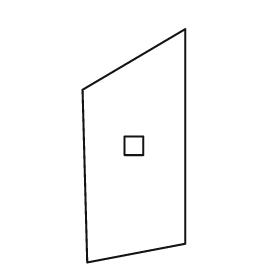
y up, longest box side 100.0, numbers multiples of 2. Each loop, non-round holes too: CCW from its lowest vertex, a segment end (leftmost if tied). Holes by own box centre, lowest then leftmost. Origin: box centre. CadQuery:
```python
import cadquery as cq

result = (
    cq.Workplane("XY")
    .moveTo(-20.0, -50.0)
    .lineTo(22.0, -42.0)
    .lineTo(22.0, 50.0)
    .lineTo(-22.0, 24.0)
    .close()
    .moveTo(-4.0, -4.0)
    .lineTo(4.0, -4.0)
    .lineTo(4.0, 4.0)
    .lineTo(-4.0, 4.0)
    .close()
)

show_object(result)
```